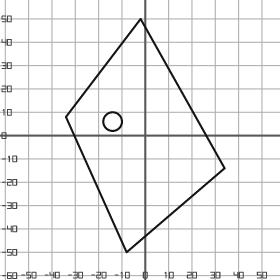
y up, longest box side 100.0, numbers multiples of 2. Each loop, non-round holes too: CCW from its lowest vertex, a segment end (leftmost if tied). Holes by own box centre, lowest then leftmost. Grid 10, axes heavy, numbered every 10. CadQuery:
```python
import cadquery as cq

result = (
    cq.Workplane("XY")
    .moveTo(-8.0, -50.0)
    .lineTo(34.0, -14.0)
    .lineTo(-2.0, 50.0)
    .lineTo(-34.0, 8.0)
    .close()
    .moveTo(-14.0, 6.0)
    .circle(4.0)
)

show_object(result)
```